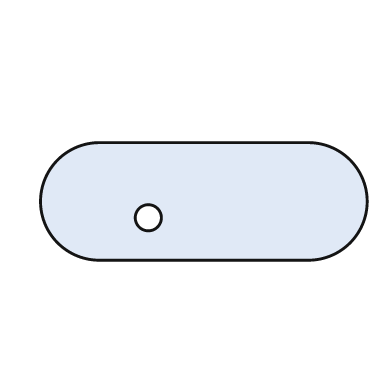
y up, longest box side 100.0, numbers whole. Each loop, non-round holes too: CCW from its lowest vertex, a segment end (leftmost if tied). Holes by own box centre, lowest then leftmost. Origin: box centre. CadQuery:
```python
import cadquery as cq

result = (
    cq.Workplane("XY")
    .moveTo(-32.0, -18.0)
    .lineTo(32.0, -18.0)
    .threePointArc((50.0, 0.0), (32.0, 18.0))
    .lineTo(-32.0, 18.0)
    .threePointArc((-50.0, 0.0), (-32.0, -18.0))
    .close()
    .moveTo(-17.0, -5.0)
    .circle(4.0)
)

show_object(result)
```